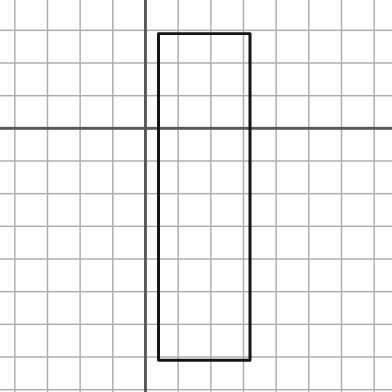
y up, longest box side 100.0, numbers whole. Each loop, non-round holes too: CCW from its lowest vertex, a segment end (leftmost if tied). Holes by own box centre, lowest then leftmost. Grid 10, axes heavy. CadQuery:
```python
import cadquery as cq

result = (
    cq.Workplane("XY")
    .moveTo(4.0, -71.0)
    .lineTo(32.0, -71.0)
    .lineTo(32.0, 29.0)
    .lineTo(4.0, 29.0)
    .close()
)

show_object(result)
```